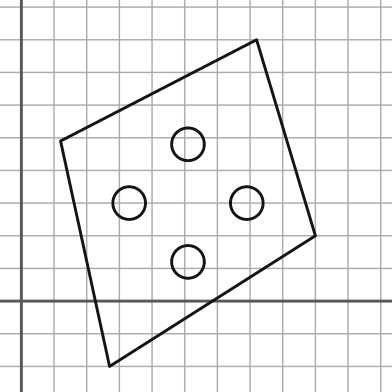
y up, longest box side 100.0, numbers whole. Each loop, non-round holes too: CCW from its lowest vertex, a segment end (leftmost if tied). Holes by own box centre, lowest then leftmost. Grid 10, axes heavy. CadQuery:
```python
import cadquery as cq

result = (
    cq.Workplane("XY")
    .moveTo(27.0, -20.0)
    .lineTo(90.0, 20.0)
    .lineTo(72.0, 80.0)
    .lineTo(12.0, 49.0)
    .close()
    .moveTo(51.0, 12.0)
    .circle(5.0)
    .moveTo(33.0, 30.0)
    .circle(5.0)
    .moveTo(69.0, 30.0)
    .circle(5.0)
    .moveTo(51.0, 48.0)
    .circle(5.0)
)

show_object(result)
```